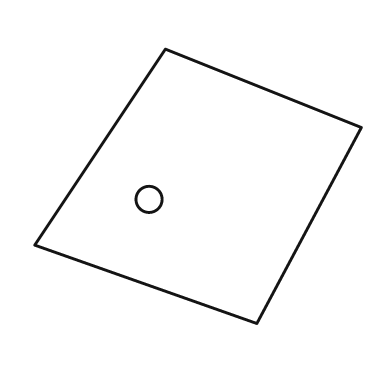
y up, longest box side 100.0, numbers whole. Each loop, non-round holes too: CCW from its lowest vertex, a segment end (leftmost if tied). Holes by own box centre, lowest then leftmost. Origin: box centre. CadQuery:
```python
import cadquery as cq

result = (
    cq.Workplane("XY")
    .moveTo(18.0, -42.0)
    .lineTo(50.0, 18.0)
    .lineTo(-10.0, 42.0)
    .lineTo(-50.0, -18.0)
    .close()
    .moveTo(-15.0, -4.0)
    .circle(4.0)
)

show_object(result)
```